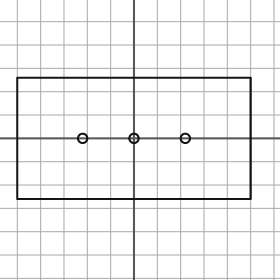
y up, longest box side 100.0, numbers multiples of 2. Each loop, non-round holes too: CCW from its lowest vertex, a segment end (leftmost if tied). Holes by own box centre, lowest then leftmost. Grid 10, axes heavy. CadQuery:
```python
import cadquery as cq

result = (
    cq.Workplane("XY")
    .moveTo(-50.0, -26.0)
    .lineTo(50.0, -26.0)
    .lineTo(50.0, 26.0)
    .lineTo(-50.0, 26.0)
    .close()
    .moveTo(-22.0, 0.0)
    .circle(2.0)
    .moveTo(0.0, 0.0)
    .circle(2.0)
    .moveTo(22.0, 0.0)
    .circle(2.0)
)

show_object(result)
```